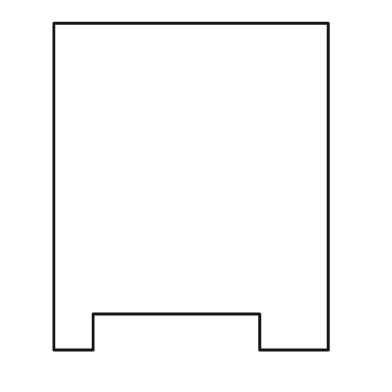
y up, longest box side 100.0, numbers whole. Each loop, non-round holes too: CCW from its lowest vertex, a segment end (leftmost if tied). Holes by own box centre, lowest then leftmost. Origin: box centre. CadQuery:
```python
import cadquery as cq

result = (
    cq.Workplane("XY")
    .moveTo(-42.0, -50.0)
    .lineTo(-30.0, -50.0)
    .lineTo(-30.0, -39.0)
    .lineTo(21.0, -39.0)
    .lineTo(21.0, -50.0)
    .lineTo(42.0, -50.0)
    .lineTo(42.0, 50.0)
    .lineTo(-42.0, 50.0)
    .close()
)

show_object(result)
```